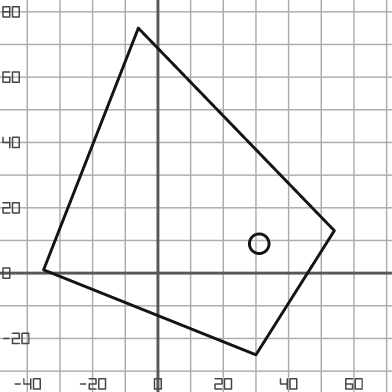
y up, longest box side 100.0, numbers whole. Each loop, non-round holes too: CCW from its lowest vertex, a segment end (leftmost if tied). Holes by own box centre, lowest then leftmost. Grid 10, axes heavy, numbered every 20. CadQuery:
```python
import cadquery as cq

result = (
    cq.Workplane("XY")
    .moveTo(30.0, -25.0)
    .lineTo(54.0, 13.0)
    .lineTo(-6.0, 75.0)
    .lineTo(-35.0, 1.0)
    .close()
    .moveTo(31.0, 9.0)
    .circle(3.0)
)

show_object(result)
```